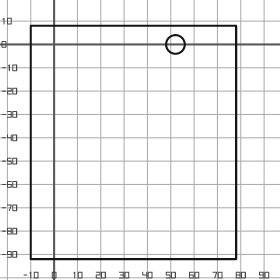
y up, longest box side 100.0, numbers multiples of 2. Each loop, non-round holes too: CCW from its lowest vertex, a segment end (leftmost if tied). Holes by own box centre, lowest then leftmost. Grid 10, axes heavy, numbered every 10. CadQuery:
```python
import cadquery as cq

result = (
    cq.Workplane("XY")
    .moveTo(-10.0, -92.0)
    .lineTo(78.0, -92.0)
    .lineTo(78.0, 8.0)
    .lineTo(-10.0, 8.0)
    .close()
    .moveTo(52.0, 0.0)
    .circle(4.0)
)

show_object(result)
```